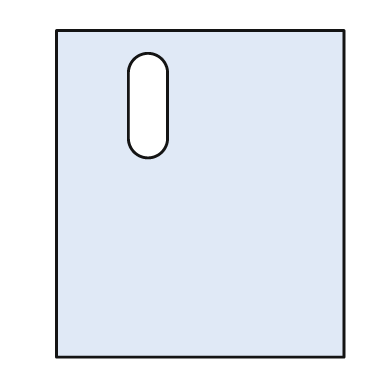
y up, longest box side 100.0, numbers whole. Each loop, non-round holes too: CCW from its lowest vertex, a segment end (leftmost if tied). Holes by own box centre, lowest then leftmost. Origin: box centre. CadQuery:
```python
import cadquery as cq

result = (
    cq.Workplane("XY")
    .moveTo(-44.0, -50.0)
    .lineTo(44.0, -50.0)
    .lineTo(44.0, 50.0)
    .lineTo(-44.0, 50.0)
    .close()
    .moveTo(-22.0, 17.0)
    .threePointArc((-16.0, 11.0), (-10.0, 17.0))
    .lineTo(-10.0, 37.0)
    .threePointArc((-16.0, 43.0), (-22.0, 37.0))
    .close()
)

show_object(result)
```